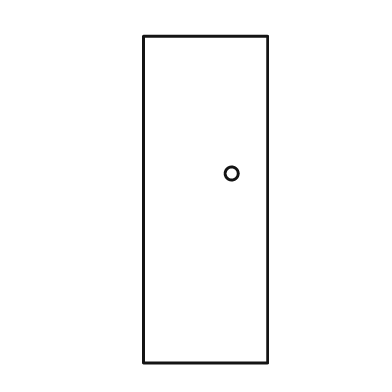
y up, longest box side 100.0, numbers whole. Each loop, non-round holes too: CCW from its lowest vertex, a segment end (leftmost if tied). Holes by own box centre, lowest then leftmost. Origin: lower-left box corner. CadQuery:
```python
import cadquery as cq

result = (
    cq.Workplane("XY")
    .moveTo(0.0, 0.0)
    .lineTo(38.0, 0.0)
    .lineTo(38.0, 100.0)
    .lineTo(0.0, 100.0)
    .close()
    .moveTo(27.0, 58.0)
    .circle(2.0)
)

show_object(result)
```